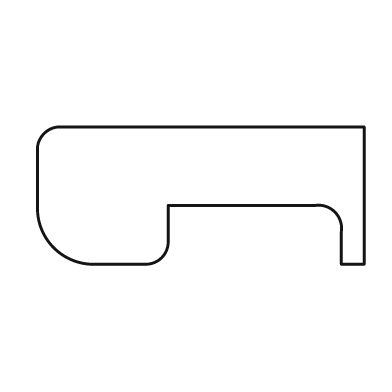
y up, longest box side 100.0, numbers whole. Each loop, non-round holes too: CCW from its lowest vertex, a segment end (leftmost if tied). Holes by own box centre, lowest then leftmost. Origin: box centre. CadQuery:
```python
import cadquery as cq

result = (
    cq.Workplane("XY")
    .moveTo(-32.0, -21.0)
    .lineTo(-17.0, -21.0)
    .threePointArc((-12.0, -19.0), (-10.0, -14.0))
    .lineTo(-10.0, -3.0)
    .lineTo(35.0, -3.0)
    .threePointArc((41.0, -5.0), (43.0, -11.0))
    .lineTo(43.0, -21.0)
    .lineTo(50.0, -21.0)
    .lineTo(50.0, 21.0)
    .lineTo(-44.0, 21.0)
    .threePointArc((-48.0, 19.0), (-50.0, 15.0))
    .lineTo(-50.0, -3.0)
    .threePointArc((-45.0, -16.0), (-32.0, -21.0))
    .close()
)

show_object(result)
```